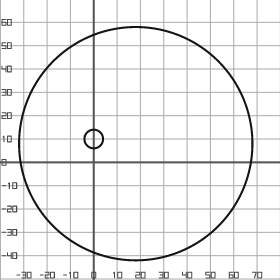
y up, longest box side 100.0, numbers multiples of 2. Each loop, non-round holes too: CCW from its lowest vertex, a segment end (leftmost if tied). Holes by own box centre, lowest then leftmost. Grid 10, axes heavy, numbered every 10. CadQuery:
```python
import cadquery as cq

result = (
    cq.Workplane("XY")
    .moveTo(18.0, 8.0)
    .circle(50.0)
    .moveTo(0.0, 10.0)
    .circle(4.0)
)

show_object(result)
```